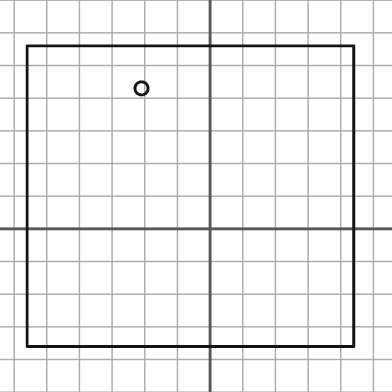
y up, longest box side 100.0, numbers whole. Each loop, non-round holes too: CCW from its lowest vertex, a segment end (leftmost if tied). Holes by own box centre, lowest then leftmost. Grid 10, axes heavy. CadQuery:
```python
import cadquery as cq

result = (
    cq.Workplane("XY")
    .moveTo(-56.0, -36.0)
    .lineTo(44.0, -36.0)
    .lineTo(44.0, 56.0)
    .lineTo(-56.0, 56.0)
    .close()
    .moveTo(-21.0, 43.0)
    .circle(2.0)
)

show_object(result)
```